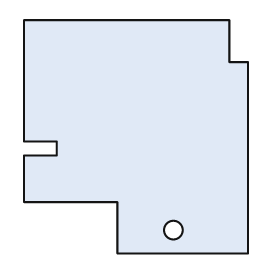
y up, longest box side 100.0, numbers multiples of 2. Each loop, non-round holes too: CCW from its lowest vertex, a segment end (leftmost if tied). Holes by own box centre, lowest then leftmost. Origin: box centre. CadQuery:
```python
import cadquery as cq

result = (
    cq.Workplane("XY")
    .moveTo(-8.0, -50.0)
    .lineTo(48.0, -50.0)
    .lineTo(48.0, 32.0)
    .lineTo(40.0, 32.0)
    .lineTo(40.0, 50.0)
    .lineTo(-48.0, 50.0)
    .lineTo(-48.0, -2.0)
    .lineTo(-34.0, -2.0)
    .lineTo(-34.0, -8.0)
    .lineTo(-48.0, -8.0)
    .lineTo(-48.0, -28.0)
    .lineTo(-8.0, -28.0)
    .close()
    .moveTo(16.0, -40.0)
    .circle(4.0)
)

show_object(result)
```